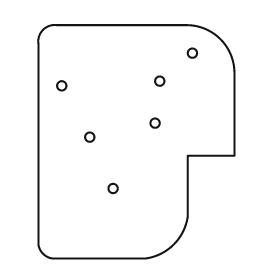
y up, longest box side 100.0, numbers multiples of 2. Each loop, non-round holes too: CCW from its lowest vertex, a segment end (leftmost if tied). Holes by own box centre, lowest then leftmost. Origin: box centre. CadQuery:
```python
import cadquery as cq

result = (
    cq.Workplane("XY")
    .moveTo(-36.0, -50.0)
    .lineTo(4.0, -50.0)
    .threePointArc((16.0, -44.0), (22.0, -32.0))
    .lineTo(22.0, -6.0)
    .lineTo(42.0, -6.0)
    .lineTo(42.0, 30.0)
    .threePointArc((36.0, 44.0), (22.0, 50.0))
    .lineTo(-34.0, 50.0)
    .threePointArc((-40.0, 48.0), (-42.0, 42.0))
    .lineTo(-42.0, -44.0)
    .threePointArc((-40.0, -48.0), (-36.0, -50.0))
    .close()
    .moveTo(-10.0, -20.0)
    .circle(2.0)
    .moveTo(-20.0, 2.0)
    .circle(2.0)
    .moveTo(8.0, 8.0)
    .circle(2.0)
    .moveTo(-32.0, 24.0)
    .circle(2.0)
    .moveTo(10.0, 26.0)
    .circle(2.0)
    .moveTo(24.0, 38.0)
    .circle(2.0)
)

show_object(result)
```